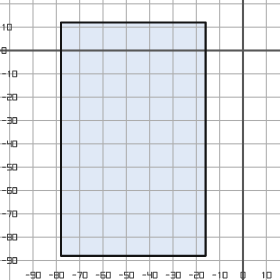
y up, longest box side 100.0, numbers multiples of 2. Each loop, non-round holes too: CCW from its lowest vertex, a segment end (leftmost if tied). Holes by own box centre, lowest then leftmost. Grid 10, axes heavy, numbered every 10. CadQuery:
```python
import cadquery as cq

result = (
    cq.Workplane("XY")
    .moveTo(-78.0, -88.0)
    .lineTo(-16.0, -88.0)
    .lineTo(-16.0, 12.0)
    .lineTo(-78.0, 12.0)
    .close()
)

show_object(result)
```